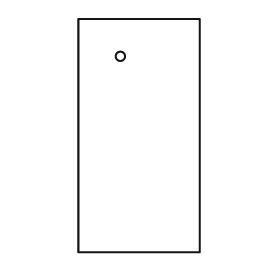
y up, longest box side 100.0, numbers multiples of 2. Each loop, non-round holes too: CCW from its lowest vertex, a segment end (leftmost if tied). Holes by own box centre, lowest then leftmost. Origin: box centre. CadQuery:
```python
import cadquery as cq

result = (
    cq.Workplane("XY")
    .moveTo(-26.0, -50.0)
    .lineTo(26.0, -50.0)
    .lineTo(26.0, 50.0)
    .lineTo(-26.0, 50.0)
    .close()
    .moveTo(-8.0, 34.0)
    .circle(2.0)
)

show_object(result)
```